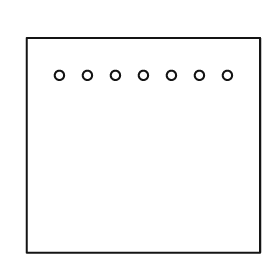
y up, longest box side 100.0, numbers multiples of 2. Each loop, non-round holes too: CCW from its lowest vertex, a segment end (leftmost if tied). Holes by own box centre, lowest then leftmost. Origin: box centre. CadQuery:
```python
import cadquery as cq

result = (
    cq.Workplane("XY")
    .moveTo(-50.0, -46.0)
    .lineTo(50.0, -46.0)
    .lineTo(50.0, 46.0)
    .lineTo(-50.0, 46.0)
    .close()
    .moveTo(-36.0, 30.0)
    .circle(2.0)
    .moveTo(-24.0, 30.0)
    .circle(2.0)
    .moveTo(-12.0, 30.0)
    .circle(2.0)
    .moveTo(0.0, 30.0)
    .circle(2.0)
    .moveTo(12.0, 30.0)
    .circle(2.0)
    .moveTo(24.0, 30.0)
    .circle(2.0)
    .moveTo(36.0, 30.0)
    .circle(2.0)
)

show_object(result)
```